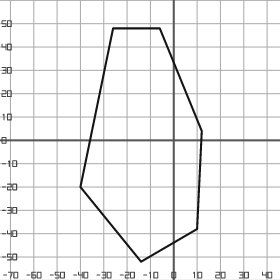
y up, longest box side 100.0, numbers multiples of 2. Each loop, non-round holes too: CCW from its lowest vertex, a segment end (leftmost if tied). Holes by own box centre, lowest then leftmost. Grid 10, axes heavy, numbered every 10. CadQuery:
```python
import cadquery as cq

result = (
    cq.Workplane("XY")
    .moveTo(-14.0, -52.0)
    .lineTo(10.0, -38.0)
    .lineTo(12.0, 4.0)
    .lineTo(-6.0, 48.0)
    .lineTo(-26.0, 48.0)
    .lineTo(-40.0, -20.0)
    .close()
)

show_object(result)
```